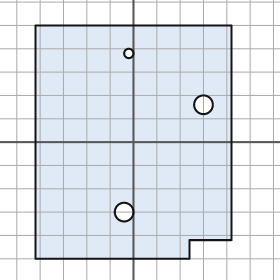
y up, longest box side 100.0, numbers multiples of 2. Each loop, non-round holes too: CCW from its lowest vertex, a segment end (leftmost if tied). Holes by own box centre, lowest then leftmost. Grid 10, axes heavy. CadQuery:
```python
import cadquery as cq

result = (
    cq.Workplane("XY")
    .moveTo(-42.0, -50.0)
    .lineTo(24.0, -50.0)
    .lineTo(24.0, -42.0)
    .lineTo(42.0, -42.0)
    .lineTo(42.0, 50.0)
    .lineTo(-42.0, 50.0)
    .close()
    .moveTo(-4.0, -30.0)
    .circle(4.0)
    .moveTo(30.0, 16.0)
    .circle(4.0)
    .moveTo(-2.0, 38.0)
    .circle(2.0)
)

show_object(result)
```